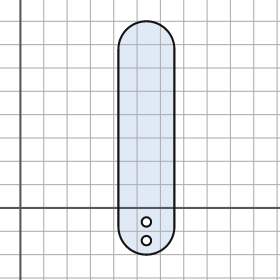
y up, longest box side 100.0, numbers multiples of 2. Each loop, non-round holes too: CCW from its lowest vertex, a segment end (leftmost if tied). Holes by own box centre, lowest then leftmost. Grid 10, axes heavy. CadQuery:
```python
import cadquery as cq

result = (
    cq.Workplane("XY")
    .moveTo(42.0, -8.0)
    .threePointArc((54.0, -20.0), (66.0, -8.0))
    .lineTo(66.0, 68.0)
    .threePointArc((54.0, 80.0), (42.0, 68.0))
    .close()
    .moveTo(54.0, -14.0)
    .circle(2.0)
    .moveTo(54.0, -6.0)
    .circle(2.0)
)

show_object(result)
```